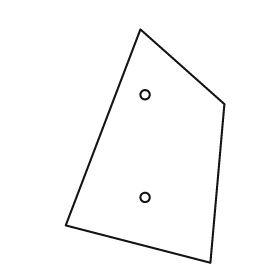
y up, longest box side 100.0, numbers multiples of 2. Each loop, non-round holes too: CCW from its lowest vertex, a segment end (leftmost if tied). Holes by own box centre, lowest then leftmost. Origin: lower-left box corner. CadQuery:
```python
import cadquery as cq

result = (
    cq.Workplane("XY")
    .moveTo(62.0, 0.0)
    .lineTo(68.0, 68.0)
    .lineTo(32.0, 100.0)
    .lineTo(0.0, 16.0)
    .close()
    .moveTo(34.0, 28.0)
    .circle(2.0)
    .moveTo(34.0, 72.0)
    .circle(2.0)
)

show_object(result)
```